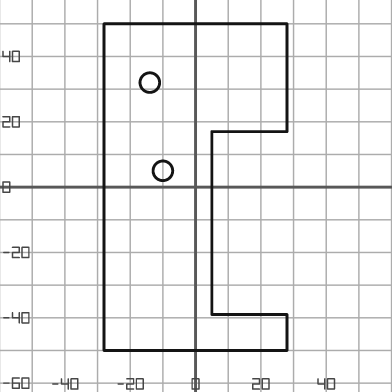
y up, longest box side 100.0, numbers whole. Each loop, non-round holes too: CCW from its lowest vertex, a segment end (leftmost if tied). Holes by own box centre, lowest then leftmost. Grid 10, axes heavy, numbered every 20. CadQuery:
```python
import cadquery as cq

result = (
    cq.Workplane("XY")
    .moveTo(-28.0, -50.0)
    .lineTo(28.0, -50.0)
    .lineTo(28.0, -39.0)
    .lineTo(5.0, -39.0)
    .lineTo(5.0, 17.0)
    .lineTo(28.0, 17.0)
    .lineTo(28.0, 50.0)
    .lineTo(-28.0, 50.0)
    .close()
    .moveTo(-10.0, 5.0)
    .circle(3.0)
    .moveTo(-14.0, 32.0)
    .circle(3.0)
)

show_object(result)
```